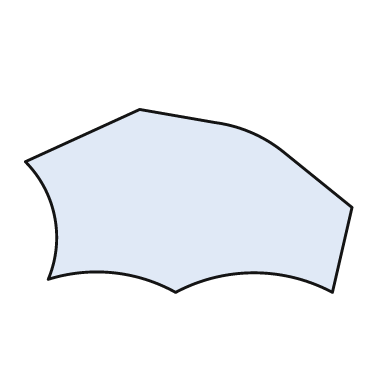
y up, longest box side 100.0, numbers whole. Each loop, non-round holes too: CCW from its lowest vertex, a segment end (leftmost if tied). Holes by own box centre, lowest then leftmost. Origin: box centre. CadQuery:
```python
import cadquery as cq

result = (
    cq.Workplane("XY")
    .moveTo(-4.0, -28.0)
    .threePointArc((20.0, -22.0), (44.0, -28.0))
    .lineTo(50.0, -2.0)
    .lineTo(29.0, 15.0)
    .threePointArc((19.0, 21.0), (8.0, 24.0))
    .lineTo(-15.0, 28.0)
    .lineTo(-50.0, 12.0)
    .threePointArc((-41.0, -5.0), (-43.0, -24.0))
    .threePointArc((-23.0, -22.0), (-4.0, -28.0))
    .close()
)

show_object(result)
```